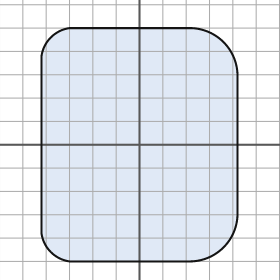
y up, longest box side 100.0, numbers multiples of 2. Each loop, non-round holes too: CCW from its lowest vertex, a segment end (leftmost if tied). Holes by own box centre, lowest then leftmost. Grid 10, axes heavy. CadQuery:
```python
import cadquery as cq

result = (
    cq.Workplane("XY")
    .moveTo(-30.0, -50.0)
    .lineTo(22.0, -50.0)
    .threePointArc((36.0, -44.0), (42.0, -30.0))
    .lineTo(42.0, 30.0)
    .threePointArc((36.0, 44.0), (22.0, 50.0))
    .lineTo(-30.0, 50.0)
    .threePointArc((-38.0, 46.0), (-42.0, 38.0))
    .lineTo(-42.0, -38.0)
    .threePointArc((-38.0, -46.0), (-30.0, -50.0))
    .close()
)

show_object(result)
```